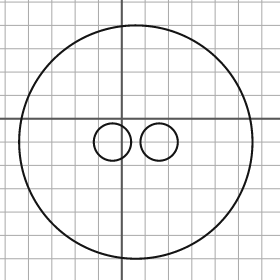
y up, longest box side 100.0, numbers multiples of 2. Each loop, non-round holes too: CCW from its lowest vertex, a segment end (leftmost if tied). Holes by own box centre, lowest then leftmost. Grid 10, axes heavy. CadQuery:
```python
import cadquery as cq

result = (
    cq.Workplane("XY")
    .moveTo(6.0, -10.0)
    .circle(50.0)
    .moveTo(-4.0, -10.0)
    .circle(8.0)
    .moveTo(16.0, -10.0)
    .circle(8.0)
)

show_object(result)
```